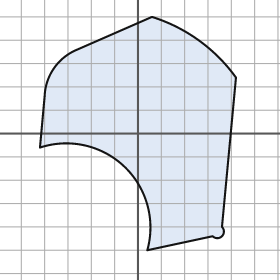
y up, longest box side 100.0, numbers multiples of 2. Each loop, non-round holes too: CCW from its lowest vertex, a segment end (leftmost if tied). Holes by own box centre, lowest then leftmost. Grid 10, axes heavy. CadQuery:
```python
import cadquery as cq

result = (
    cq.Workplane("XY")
    .moveTo(4.0, -50.0)
    .lineTo(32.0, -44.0)
    .threePointArc((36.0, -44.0), (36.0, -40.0))
    .lineTo(42.0, 24.0)
    .threePointArc((26.0, 40.0), (6.0, 50.0))
    .lineTo(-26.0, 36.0)
    .threePointArc((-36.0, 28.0), (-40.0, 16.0))
    .lineTo(-42.0, -6.0)
    .threePointArc((-6.0, -14.0), (4.0, -50.0))
    .close()
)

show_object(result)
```